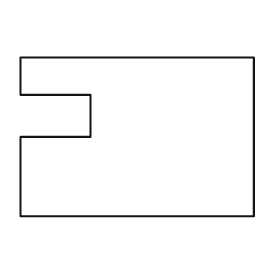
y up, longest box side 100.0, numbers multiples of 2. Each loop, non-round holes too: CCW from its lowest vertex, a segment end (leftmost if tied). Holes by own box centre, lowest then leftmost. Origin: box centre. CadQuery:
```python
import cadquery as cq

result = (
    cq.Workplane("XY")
    .moveTo(-50.0, -34.0)
    .lineTo(50.0, -34.0)
    .lineTo(50.0, 34.0)
    .lineTo(-50.0, 34.0)
    .lineTo(-50.0, 18.0)
    .lineTo(-20.0, 18.0)
    .lineTo(-20.0, 0.0)
    .lineTo(-50.0, 0.0)
    .close()
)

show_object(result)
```